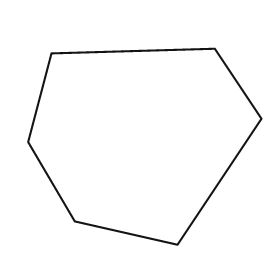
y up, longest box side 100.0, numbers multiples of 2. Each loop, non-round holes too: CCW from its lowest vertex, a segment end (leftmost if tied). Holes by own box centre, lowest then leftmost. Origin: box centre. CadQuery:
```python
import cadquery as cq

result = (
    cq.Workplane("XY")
    .moveTo(14.0, -42.0)
    .lineTo(50.0, 12.0)
    .lineTo(30.0, 42.0)
    .lineTo(-40.0, 40.0)
    .lineTo(-50.0, 2.0)
    .lineTo(-30.0, -32.0)
    .close()
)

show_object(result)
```